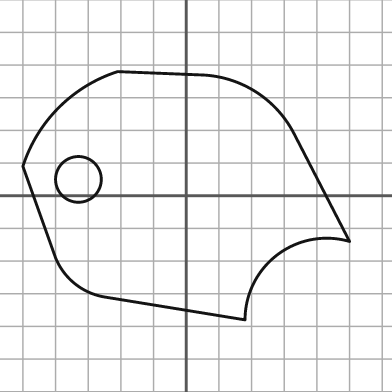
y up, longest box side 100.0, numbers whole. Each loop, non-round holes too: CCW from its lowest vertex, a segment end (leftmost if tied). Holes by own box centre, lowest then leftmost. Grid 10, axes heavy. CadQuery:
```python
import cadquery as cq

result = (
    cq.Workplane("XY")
    .moveTo(18.0, -38.0)
    .threePointArc((28.0, -18.0), (50.0, -14.0))
    .lineTo(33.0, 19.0)
    .threePointArc((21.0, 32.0), (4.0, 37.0))
    .lineTo(-21.0, 38.0)
    .threePointArc((-39.0, 27.0), (-50.0, 9.0))
    .lineTo(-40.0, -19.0)
    .threePointArc((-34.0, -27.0), (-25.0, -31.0))
    .close()
    .moveTo(-33.0, 5.0)
    .circle(7.0)
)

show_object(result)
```